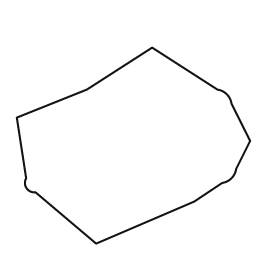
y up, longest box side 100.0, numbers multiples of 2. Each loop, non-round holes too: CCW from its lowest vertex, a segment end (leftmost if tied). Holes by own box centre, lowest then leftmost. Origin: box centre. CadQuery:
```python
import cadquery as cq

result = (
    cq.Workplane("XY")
    .moveTo(-16.0, -42.0)
    .lineTo(26.0, -24.0)
    .lineTo(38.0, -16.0)
    .threePointArc((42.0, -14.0), (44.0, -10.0))
    .lineTo(50.0, 2.0)
    .lineTo(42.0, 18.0)
    .threePointArc((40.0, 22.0), (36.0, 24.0))
    .lineTo(8.0, 42.0)
    .lineTo(-20.0, 24.0)
    .lineTo(-50.0, 12.0)
    .lineTo(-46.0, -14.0)
    .threePointArc((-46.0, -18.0), (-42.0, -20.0))
    .close()
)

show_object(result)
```